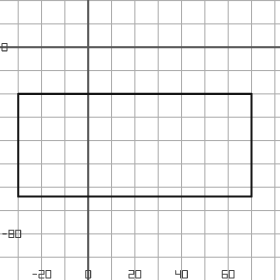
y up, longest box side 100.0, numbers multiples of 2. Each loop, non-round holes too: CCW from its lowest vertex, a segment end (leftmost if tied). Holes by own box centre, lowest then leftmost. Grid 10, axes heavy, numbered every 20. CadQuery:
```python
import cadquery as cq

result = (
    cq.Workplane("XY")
    .moveTo(-30.0, -64.0)
    .lineTo(70.0, -64.0)
    .lineTo(70.0, -20.0)
    .lineTo(-30.0, -20.0)
    .close()
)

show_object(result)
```